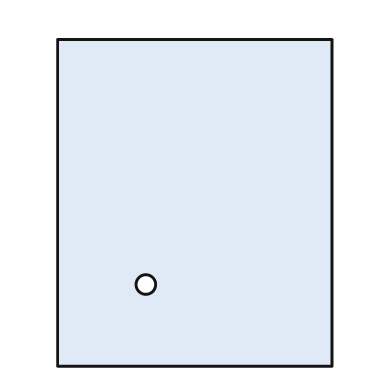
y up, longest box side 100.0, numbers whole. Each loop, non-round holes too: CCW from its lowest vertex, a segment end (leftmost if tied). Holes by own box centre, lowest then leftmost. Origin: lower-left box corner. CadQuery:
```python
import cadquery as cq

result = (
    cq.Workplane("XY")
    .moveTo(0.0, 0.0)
    .lineTo(84.0, 0.0)
    .lineTo(84.0, 100.0)
    .lineTo(0.0, 100.0)
    .close()
    .moveTo(27.0, 25.0)
    .circle(3.0)
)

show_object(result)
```